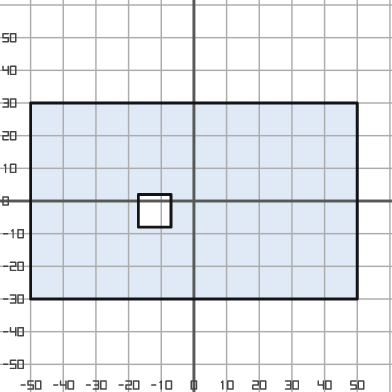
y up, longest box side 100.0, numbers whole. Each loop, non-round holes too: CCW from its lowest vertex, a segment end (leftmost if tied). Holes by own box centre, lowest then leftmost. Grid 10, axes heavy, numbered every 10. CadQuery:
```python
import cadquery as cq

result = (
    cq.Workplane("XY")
    .moveTo(-50.0, -30.0)
    .lineTo(50.0, -30.0)
    .lineTo(50.0, 30.0)
    .lineTo(-50.0, 30.0)
    .close()
    .moveTo(-17.0, -8.0)
    .lineTo(-7.0, -8.0)
    .lineTo(-7.0, 2.0)
    .lineTo(-17.0, 2.0)
    .close()
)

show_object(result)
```